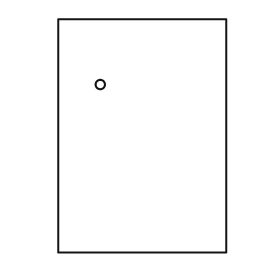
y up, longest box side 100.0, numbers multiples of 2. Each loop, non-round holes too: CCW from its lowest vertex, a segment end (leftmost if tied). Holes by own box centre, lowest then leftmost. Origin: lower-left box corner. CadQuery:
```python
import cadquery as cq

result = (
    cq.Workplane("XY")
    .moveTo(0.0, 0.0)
    .lineTo(72.0, 0.0)
    .lineTo(72.0, 100.0)
    .lineTo(0.0, 100.0)
    .close()
    .moveTo(18.0, 72.0)
    .circle(2.0)
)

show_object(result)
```